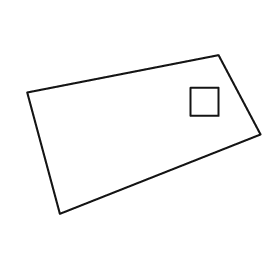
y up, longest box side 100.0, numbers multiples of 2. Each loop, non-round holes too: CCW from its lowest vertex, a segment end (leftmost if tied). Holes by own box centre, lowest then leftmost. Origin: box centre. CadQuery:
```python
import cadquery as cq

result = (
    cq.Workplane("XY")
    .moveTo(-36.0, -34.0)
    .lineTo(50.0, 0.0)
    .lineTo(32.0, 34.0)
    .lineTo(-50.0, 18.0)
    .close()
    .moveTo(20.0, 8.0)
    .lineTo(32.0, 8.0)
    .lineTo(32.0, 20.0)
    .lineTo(20.0, 20.0)
    .close()
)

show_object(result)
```